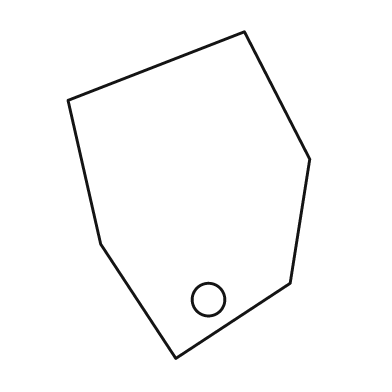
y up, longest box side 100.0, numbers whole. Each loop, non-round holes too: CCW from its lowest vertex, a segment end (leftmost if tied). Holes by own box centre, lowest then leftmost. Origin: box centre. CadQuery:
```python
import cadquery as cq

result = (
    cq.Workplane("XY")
    .moveTo(-4.0, -50.0)
    .lineTo(31.0, -27.0)
    .lineTo(37.0, 11.0)
    .lineTo(17.0, 50.0)
    .lineTo(-37.0, 29.0)
    .lineTo(-27.0, -15.0)
    .close()
    .moveTo(6.0, -32.0)
    .circle(5.0)
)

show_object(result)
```